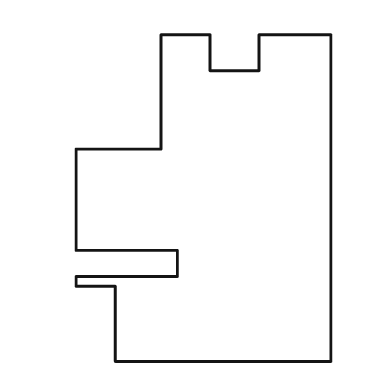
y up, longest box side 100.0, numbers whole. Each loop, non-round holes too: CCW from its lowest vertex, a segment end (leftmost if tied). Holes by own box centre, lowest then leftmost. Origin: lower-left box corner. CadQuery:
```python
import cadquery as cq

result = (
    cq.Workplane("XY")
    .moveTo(12.0, 0.0)
    .lineTo(78.0, 0.0)
    .lineTo(78.0, 100.0)
    .lineTo(56.0, 100.0)
    .lineTo(56.0, 89.0)
    .lineTo(41.0, 89.0)
    .lineTo(41.0, 100.0)
    .lineTo(26.0, 100.0)
    .lineTo(26.0, 65.0)
    .lineTo(0.0, 65.0)
    .lineTo(0.0, 34.0)
    .lineTo(31.0, 34.0)
    .lineTo(31.0, 26.0)
    .lineTo(0.0, 26.0)
    .lineTo(0.0, 23.0)
    .lineTo(12.0, 23.0)
    .close()
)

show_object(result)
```